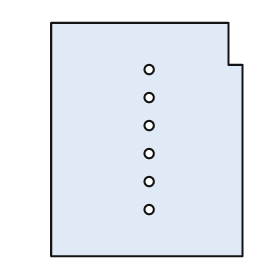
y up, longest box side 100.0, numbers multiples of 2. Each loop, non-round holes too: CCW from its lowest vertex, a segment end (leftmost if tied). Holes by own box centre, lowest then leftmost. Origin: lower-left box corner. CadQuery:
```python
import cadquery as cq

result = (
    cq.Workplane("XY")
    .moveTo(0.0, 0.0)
    .lineTo(82.0, 0.0)
    .lineTo(82.0, 82.0)
    .lineTo(76.0, 82.0)
    .lineTo(76.0, 100.0)
    .lineTo(0.0, 100.0)
    .close()
    .moveTo(42.0, 20.0)
    .circle(2.0)
    .moveTo(42.0, 32.0)
    .circle(2.0)
    .moveTo(42.0, 44.0)
    .circle(2.0)
    .moveTo(42.0, 56.0)
    .circle(2.0)
    .moveTo(42.0, 68.0)
    .circle(2.0)
    .moveTo(42.0, 80.0)
    .circle(2.0)
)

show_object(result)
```